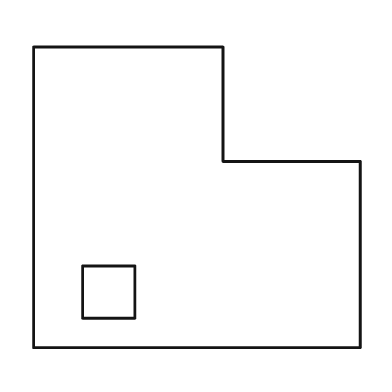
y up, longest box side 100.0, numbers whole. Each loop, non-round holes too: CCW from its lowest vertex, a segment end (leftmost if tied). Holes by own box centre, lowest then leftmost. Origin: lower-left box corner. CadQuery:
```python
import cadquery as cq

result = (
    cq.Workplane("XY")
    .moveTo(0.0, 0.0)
    .lineTo(100.0, 0.0)
    .lineTo(100.0, 57.0)
    .lineTo(58.0, 57.0)
    .lineTo(58.0, 92.0)
    .lineTo(0.0, 92.0)
    .close()
    .moveTo(15.0, 9.0)
    .lineTo(31.0, 9.0)
    .lineTo(31.0, 25.0)
    .lineTo(15.0, 25.0)
    .close()
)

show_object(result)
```